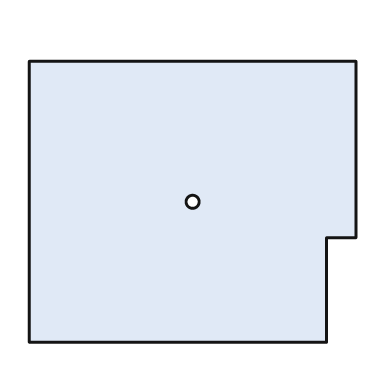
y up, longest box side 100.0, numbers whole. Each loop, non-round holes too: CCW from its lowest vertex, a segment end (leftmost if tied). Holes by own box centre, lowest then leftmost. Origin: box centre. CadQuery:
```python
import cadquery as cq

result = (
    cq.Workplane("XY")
    .moveTo(-50.0, -43.0)
    .lineTo(41.0, -43.0)
    .lineTo(41.0, -11.0)
    .lineTo(50.0, -11.0)
    .lineTo(50.0, 43.0)
    .lineTo(-50.0, 43.0)
    .close()
    .moveTo(0.0, 0.0)
    .circle(2.0)
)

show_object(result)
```